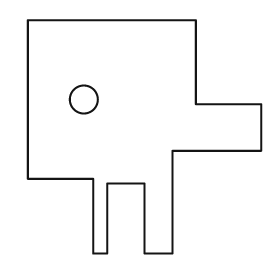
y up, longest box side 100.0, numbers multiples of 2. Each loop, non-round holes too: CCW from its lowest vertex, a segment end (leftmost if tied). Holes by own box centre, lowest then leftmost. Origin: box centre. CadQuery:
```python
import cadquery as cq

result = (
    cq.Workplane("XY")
    .moveTo(-22.0, -50.0)
    .lineTo(-16.0, -50.0)
    .lineTo(-16.0, -20.0)
    .lineTo(0.0, -20.0)
    .lineTo(0.0, -50.0)
    .lineTo(12.0, -50.0)
    .lineTo(12.0, -6.0)
    .lineTo(50.0, -6.0)
    .lineTo(50.0, 14.0)
    .lineTo(22.0, 14.0)
    .lineTo(22.0, 50.0)
    .lineTo(-50.0, 50.0)
    .lineTo(-50.0, -18.0)
    .lineTo(-22.0, -18.0)
    .close()
    .moveTo(-26.0, 16.0)
    .circle(6.0)
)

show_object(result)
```